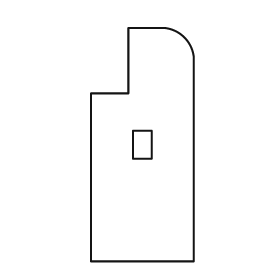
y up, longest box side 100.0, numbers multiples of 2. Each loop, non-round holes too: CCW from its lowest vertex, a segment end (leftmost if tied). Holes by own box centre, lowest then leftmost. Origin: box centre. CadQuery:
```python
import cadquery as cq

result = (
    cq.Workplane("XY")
    .moveTo(-22.0, -50.0)
    .lineTo(22.0, -50.0)
    .lineTo(22.0, 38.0)
    .threePointArc((18.0, 46.0), (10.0, 50.0))
    .lineTo(-6.0, 50.0)
    .lineTo(-6.0, 22.0)
    .lineTo(-22.0, 22.0)
    .close()
    .moveTo(-4.0, -6.0)
    .lineTo(4.0, -6.0)
    .lineTo(4.0, 6.0)
    .lineTo(-4.0, 6.0)
    .close()
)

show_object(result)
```